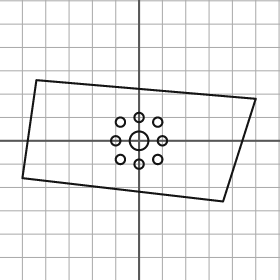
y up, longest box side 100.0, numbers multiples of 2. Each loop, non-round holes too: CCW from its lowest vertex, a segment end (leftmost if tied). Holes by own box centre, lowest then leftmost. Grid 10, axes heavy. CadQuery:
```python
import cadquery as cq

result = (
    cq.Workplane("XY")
    .moveTo(36.0, -26.0)
    .lineTo(50.0, 18.0)
    .lineTo(-44.0, 26.0)
    .lineTo(-50.0, -16.0)
    .close()
    .moveTo(0.0, -10.0)
    .circle(2.0)
    .moveTo(-8.0, -8.0)
    .circle(2.0)
    .moveTo(8.0, -8.0)
    .circle(2.0)
    .moveTo(-10.0, 0.0)
    .circle(2.0)
    .moveTo(0.0, 0.0)
    .circle(4.0)
    .moveTo(10.0, 0.0)
    .circle(2.0)
    .moveTo(-8.0, 8.0)
    .circle(2.0)
    .moveTo(8.0, 8.0)
    .circle(2.0)
    .moveTo(0.0, 10.0)
    .circle(2.0)
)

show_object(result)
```